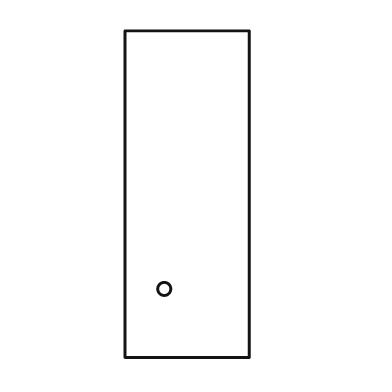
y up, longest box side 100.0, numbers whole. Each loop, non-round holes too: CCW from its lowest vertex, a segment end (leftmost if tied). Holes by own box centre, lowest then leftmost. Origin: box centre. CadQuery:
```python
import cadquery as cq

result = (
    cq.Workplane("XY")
    .moveTo(-19.0, -50.0)
    .lineTo(19.0, -50.0)
    .lineTo(19.0, 50.0)
    .lineTo(-19.0, 50.0)
    .close()
    .moveTo(-7.0, -29.0)
    .circle(2.0)
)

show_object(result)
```